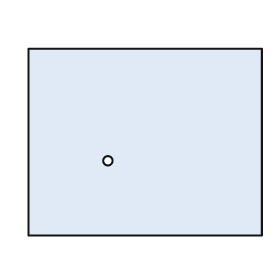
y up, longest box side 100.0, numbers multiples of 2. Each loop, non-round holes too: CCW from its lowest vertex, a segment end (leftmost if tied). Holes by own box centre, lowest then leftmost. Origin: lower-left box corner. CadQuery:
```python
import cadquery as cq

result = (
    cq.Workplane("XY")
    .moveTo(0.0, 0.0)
    .lineTo(100.0, 0.0)
    .lineTo(100.0, 80.0)
    .lineTo(0.0, 80.0)
    .close()
    .moveTo(34.0, 32.0)
    .circle(2.0)
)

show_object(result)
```